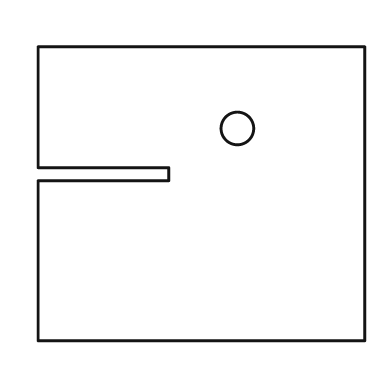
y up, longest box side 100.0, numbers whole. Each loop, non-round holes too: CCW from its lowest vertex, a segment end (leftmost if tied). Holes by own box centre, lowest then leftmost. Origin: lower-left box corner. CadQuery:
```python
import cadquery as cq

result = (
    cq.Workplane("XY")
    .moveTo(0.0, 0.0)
    .lineTo(100.0, 0.0)
    .lineTo(100.0, 90.0)
    .lineTo(0.0, 90.0)
    .lineTo(0.0, 53.0)
    .lineTo(40.0, 53.0)
    .lineTo(40.0, 49.0)
    .lineTo(0.0, 49.0)
    .close()
    .moveTo(61.0, 65.0)
    .circle(5.0)
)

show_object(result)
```